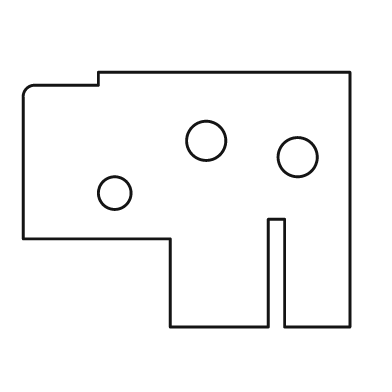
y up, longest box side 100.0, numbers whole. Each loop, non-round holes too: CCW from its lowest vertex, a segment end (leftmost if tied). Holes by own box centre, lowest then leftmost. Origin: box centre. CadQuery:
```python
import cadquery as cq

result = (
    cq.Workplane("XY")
    .moveTo(-5.0, -39.0)
    .lineTo(25.0, -39.0)
    .lineTo(25.0, -6.0)
    .lineTo(30.0, -6.0)
    .lineTo(30.0, -39.0)
    .lineTo(50.0, -39.0)
    .lineTo(50.0, 39.0)
    .lineTo(-27.0, 39.0)
    .lineTo(-27.0, 35.0)
    .lineTo(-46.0, 35.0)
    .threePointArc((-49.0, 34.0), (-50.0, 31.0))
    .lineTo(-50.0, -12.0)
    .lineTo(-5.0, -12.0)
    .close()
    .moveTo(-22.0, 2.0)
    .circle(5.0)
    .moveTo(34.0, 13.0)
    .circle(6.0)
    .moveTo(6.0, 18.0)
    .circle(6.0)
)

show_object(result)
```